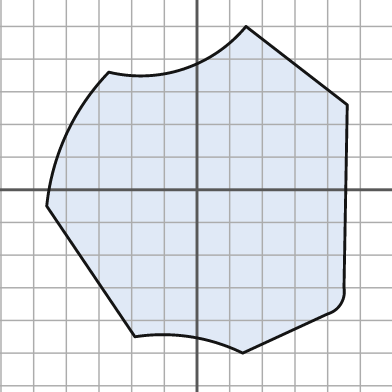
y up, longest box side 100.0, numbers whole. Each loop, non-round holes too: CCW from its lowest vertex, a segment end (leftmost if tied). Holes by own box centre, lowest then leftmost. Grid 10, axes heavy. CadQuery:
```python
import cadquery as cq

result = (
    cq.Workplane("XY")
    .moveTo(14.0, -50.0)
    .lineTo(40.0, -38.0)
    .threePointArc((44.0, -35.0), (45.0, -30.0))
    .lineTo(46.0, 26.0)
    .lineTo(15.0, 50.0)
    .threePointArc((-4.0, 37.0), (-27.0, 36.0))
    .threePointArc((-40.0, 17.0), (-46.0, -5.0))
    .lineTo(-19.0, -45.0)
    .threePointArc((-2.0, -45.0), (14.0, -50.0))
    .close()
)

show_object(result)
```